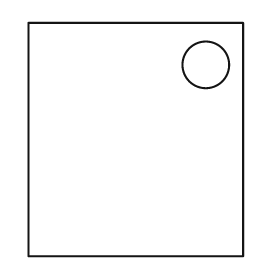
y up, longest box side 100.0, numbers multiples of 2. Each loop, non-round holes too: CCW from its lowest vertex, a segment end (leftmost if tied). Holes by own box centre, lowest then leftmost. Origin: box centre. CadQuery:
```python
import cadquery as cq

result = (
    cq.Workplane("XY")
    .moveTo(-46.0, -50.0)
    .lineTo(46.0, -50.0)
    .lineTo(46.0, 50.0)
    .lineTo(-46.0, 50.0)
    .close()
    .moveTo(30.0, 32.0)
    .circle(10.0)
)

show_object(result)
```